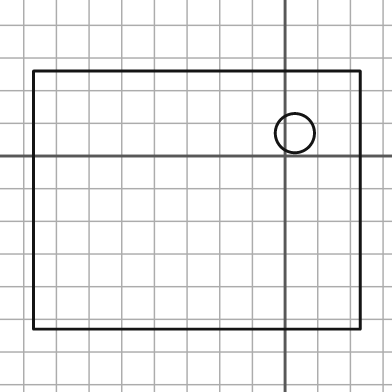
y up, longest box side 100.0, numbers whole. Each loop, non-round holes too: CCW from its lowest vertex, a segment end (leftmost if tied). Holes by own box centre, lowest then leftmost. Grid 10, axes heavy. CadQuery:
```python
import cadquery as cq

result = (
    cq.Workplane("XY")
    .moveTo(-77.0, -53.0)
    .lineTo(23.0, -53.0)
    .lineTo(23.0, 26.0)
    .lineTo(-77.0, 26.0)
    .close()
    .moveTo(3.0, 7.0)
    .circle(6.0)
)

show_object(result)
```